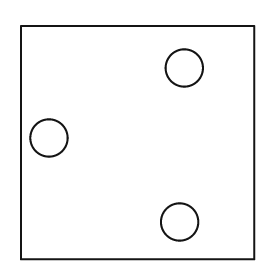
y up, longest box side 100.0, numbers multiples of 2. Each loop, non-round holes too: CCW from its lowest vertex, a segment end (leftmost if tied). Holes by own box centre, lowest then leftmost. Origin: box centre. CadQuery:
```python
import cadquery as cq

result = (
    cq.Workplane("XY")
    .moveTo(-50.0, -50.0)
    .lineTo(50.0, -50.0)
    .lineTo(50.0, 50.0)
    .lineTo(-50.0, 50.0)
    .close()
    .moveTo(18.0, -34.0)
    .circle(8.0)
    .moveTo(-38.0, 2.0)
    .circle(8.0)
    .moveTo(20.0, 32.0)
    .circle(8.0)
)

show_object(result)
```